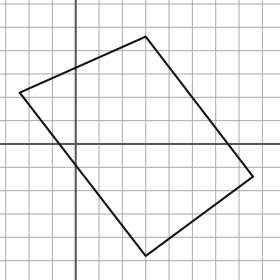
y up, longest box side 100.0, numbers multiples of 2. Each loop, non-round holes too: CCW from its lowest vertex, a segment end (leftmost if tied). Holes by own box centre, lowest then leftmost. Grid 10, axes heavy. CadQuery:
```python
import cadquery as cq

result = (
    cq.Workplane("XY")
    .moveTo(30.0, -48.0)
    .lineTo(76.0, -14.0)
    .lineTo(30.0, 46.0)
    .lineTo(-24.0, 22.0)
    .close()
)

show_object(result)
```